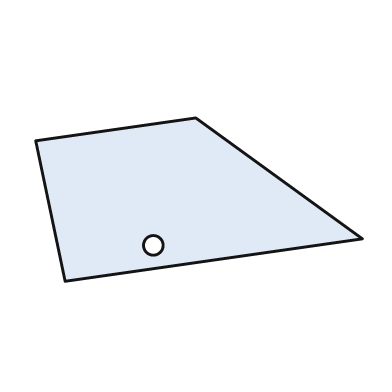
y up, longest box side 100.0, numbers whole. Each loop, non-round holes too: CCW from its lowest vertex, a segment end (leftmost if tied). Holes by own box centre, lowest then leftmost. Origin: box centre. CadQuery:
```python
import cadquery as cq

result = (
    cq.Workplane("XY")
    .moveTo(-41.0, -25.0)
    .lineTo(50.0, -12.0)
    .lineTo(-1.0, 25.0)
    .lineTo(-50.0, 18.0)
    .close()
    .moveTo(-14.0, -14.0)
    .circle(3.0)
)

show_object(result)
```